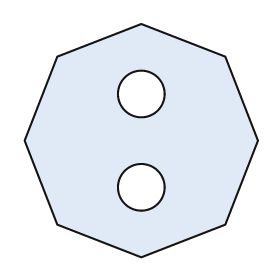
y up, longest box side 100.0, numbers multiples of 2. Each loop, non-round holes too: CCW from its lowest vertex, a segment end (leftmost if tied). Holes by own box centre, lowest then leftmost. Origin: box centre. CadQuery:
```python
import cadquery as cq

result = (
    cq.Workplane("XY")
    .moveTo(0.0, -50.0)
    .lineTo(36.0, -36.0)
    .lineTo(50.0, 0.0)
    .lineTo(36.0, 36.0)
    .lineTo(0.0, 50.0)
    .lineTo(-36.0, 36.0)
    .lineTo(-50.0, 0.0)
    .lineTo(-36.0, -36.0)
    .close()
    .moveTo(0.0, -20.0)
    .circle(10.0)
    .moveTo(0.0, 20.0)
    .circle(10.0)
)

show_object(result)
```